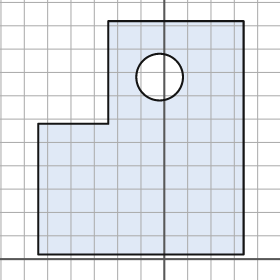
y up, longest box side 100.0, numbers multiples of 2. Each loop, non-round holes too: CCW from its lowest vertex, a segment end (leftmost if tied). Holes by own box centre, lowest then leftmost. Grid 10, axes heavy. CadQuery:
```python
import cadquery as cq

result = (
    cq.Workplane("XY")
    .moveTo(-54.0, 2.0)
    .lineTo(34.0, 2.0)
    .lineTo(34.0, 102.0)
    .lineTo(-24.0, 102.0)
    .lineTo(-24.0, 58.0)
    .lineTo(-54.0, 58.0)
    .close()
    .moveTo(-2.0, 78.0)
    .circle(10.0)
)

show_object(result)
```